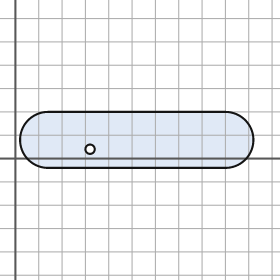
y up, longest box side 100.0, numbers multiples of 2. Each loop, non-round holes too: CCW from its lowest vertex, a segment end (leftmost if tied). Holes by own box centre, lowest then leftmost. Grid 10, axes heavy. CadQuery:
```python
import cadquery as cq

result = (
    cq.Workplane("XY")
    .moveTo(14.0, -4.0)
    .lineTo(90.0, -4.0)
    .threePointArc((102.0, 8.0), (90.0, 20.0))
    .lineTo(14.0, 20.0)
    .threePointArc((2.0, 8.0), (14.0, -4.0))
    .close()
    .moveTo(32.0, 4.0)
    .circle(2.0)
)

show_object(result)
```